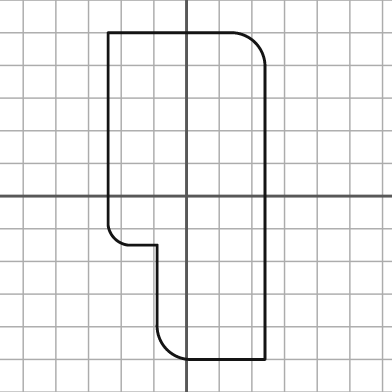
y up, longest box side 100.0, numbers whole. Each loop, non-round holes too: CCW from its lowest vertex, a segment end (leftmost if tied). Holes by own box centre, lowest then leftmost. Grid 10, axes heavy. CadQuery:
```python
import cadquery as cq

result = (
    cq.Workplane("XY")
    .moveTo(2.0, -50.0)
    .lineTo(24.0, -50.0)
    .lineTo(24.0, 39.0)
    .threePointArc((21.0, 47.0), (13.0, 50.0))
    .lineTo(-24.0, 50.0)
    .lineTo(-24.0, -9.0)
    .threePointArc((-22.0, -13.0), (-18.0, -15.0))
    .lineTo(-9.0, -15.0)
    .lineTo(-9.0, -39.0)
    .threePointArc((-6.0, -47.0), (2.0, -50.0))
    .close()
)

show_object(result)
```